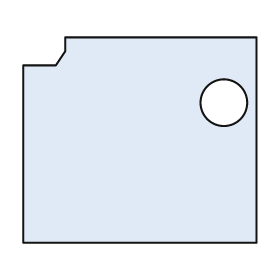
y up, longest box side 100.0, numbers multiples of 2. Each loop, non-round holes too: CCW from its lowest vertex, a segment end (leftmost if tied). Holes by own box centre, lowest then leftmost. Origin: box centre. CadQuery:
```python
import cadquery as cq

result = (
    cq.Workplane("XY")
    .moveTo(-50.0, -44.0)
    .lineTo(50.0, -44.0)
    .lineTo(50.0, 44.0)
    .lineTo(-32.0, 44.0)
    .lineTo(-32.0, 38.0)
    .lineTo(-36.0, 32.0)
    .lineTo(-50.0, 32.0)
    .close()
    .moveTo(36.0, 16.0)
    .circle(10.0)
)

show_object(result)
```